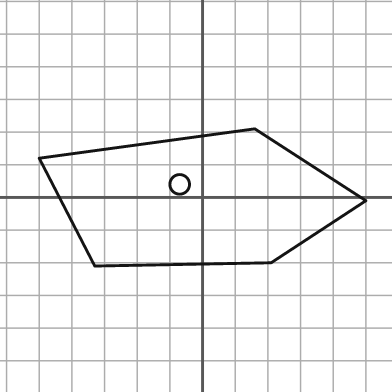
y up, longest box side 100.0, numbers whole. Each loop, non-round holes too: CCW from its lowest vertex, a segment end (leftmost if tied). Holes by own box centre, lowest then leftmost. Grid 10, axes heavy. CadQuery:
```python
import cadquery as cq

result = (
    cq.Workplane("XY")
    .moveTo(-33.0, -21.0)
    .lineTo(21.0, -20.0)
    .lineTo(50.0, -1.0)
    .lineTo(16.0, 21.0)
    .lineTo(-50.0, 12.0)
    .close()
    .moveTo(-7.0, 4.0)
    .circle(3.0)
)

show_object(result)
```